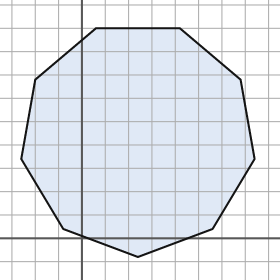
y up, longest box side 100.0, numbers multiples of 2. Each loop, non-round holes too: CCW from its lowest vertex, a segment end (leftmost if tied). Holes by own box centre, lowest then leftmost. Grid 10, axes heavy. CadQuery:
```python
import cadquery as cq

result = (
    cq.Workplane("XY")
    .moveTo(24.0, -8.0)
    .lineTo(56.0, 4.0)
    .lineTo(74.0, 34.0)
    .lineTo(68.0, 68.0)
    .lineTo(42.0, 90.0)
    .lineTo(6.0, 90.0)
    .lineTo(-20.0, 68.0)
    .lineTo(-26.0, 34.0)
    .lineTo(-8.0, 4.0)
    .close()
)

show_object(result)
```